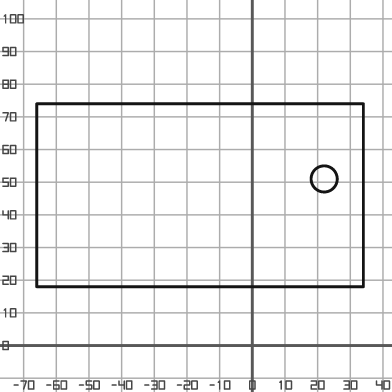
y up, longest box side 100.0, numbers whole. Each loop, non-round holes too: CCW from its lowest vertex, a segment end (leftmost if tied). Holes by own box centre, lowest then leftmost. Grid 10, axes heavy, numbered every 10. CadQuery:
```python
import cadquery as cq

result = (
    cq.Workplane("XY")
    .moveTo(-66.0, 18.0)
    .lineTo(34.0, 18.0)
    .lineTo(34.0, 74.0)
    .lineTo(-66.0, 74.0)
    .close()
    .moveTo(22.0, 51.0)
    .circle(4.0)
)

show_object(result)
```